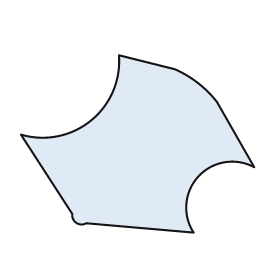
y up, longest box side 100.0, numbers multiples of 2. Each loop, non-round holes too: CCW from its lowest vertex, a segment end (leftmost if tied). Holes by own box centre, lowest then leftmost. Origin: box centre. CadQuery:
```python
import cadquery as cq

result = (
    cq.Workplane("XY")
    .moveTo(24.0, -38.0)
    .threePointArc((26.0, -14.0), (50.0, -10.0))
    .lineTo(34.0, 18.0)
    .threePointArc((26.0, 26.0), (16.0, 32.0))
    .lineTo(-8.0, 38.0)
    .threePointArc((-20.0, 10.0), (-50.0, 4.0))
    .lineTo(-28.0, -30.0)
    .threePointArc((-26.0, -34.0), (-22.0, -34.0))
    .close()
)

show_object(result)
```